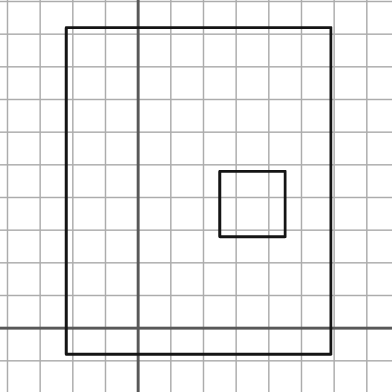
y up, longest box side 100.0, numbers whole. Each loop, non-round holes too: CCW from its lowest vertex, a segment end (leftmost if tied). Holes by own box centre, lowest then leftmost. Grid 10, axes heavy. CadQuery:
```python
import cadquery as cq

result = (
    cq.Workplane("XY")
    .moveTo(-22.0, -8.0)
    .lineTo(59.0, -8.0)
    .lineTo(59.0, 92.0)
    .lineTo(-22.0, 92.0)
    .close()
    .moveTo(25.0, 28.0)
    .lineTo(45.0, 28.0)
    .lineTo(45.0, 48.0)
    .lineTo(25.0, 48.0)
    .close()
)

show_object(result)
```